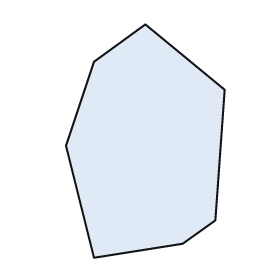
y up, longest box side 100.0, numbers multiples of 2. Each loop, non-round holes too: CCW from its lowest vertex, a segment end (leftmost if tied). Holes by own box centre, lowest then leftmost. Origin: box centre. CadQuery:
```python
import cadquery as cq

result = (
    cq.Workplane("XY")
    .moveTo(-22.0, -50.0)
    .lineTo(16.0, -44.0)
    .lineTo(30.0, -34.0)
    .lineTo(34.0, 22.0)
    .lineTo(0.0, 50.0)
    .lineTo(-22.0, 34.0)
    .lineTo(-34.0, -2.0)
    .close()
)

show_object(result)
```